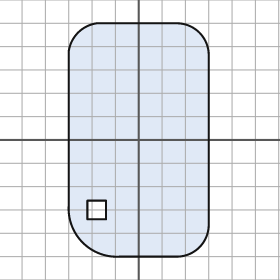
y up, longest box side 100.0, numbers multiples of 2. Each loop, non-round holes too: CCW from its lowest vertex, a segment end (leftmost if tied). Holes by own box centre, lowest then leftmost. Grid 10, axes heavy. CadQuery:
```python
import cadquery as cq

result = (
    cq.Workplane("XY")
    .moveTo(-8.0, -50.0)
    .lineTo(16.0, -50.0)
    .threePointArc((26.0, -46.0), (30.0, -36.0))
    .lineTo(30.0, 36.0)
    .threePointArc((26.0, 46.0), (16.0, 50.0))
    .lineTo(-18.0, 50.0)
    .threePointArc((-26.0, 46.0), (-30.0, 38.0))
    .lineTo(-30.0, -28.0)
    .threePointArc((-24.0, -44.0), (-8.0, -50.0))
    .close()
    .moveTo(-22.0, -34.0)
    .lineTo(-14.0, -34.0)
    .lineTo(-14.0, -26.0)
    .lineTo(-22.0, -26.0)
    .close()
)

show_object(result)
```